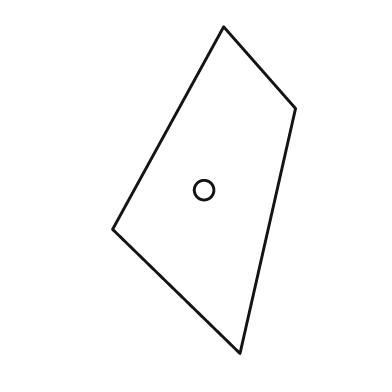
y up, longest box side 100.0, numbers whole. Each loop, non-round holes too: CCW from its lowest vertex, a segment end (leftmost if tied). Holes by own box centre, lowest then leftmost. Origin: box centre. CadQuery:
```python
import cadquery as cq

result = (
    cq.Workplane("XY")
    .moveTo(11.0, -50.0)
    .lineTo(28.0, 25.0)
    .lineTo(6.0, 50.0)
    .lineTo(-28.0, -12.0)
    .close()
    .moveTo(0.0, 0.0)
    .circle(3.0)
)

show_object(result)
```